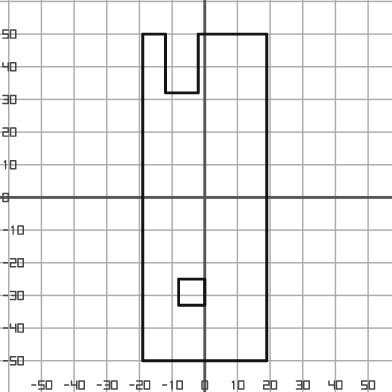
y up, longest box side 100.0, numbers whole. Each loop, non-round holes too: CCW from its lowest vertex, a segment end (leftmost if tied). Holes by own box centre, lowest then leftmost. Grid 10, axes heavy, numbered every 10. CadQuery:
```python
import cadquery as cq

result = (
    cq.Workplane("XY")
    .moveTo(-19.0, -50.0)
    .lineTo(19.0, -50.0)
    .lineTo(19.0, 50.0)
    .lineTo(-2.0, 50.0)
    .lineTo(-2.0, 32.0)
    .lineTo(-12.0, 32.0)
    .lineTo(-12.0, 50.0)
    .lineTo(-19.0, 50.0)
    .close()
    .moveTo(-8.0, -33.0)
    .lineTo(0.0, -33.0)
    .lineTo(0.0, -25.0)
    .lineTo(-8.0, -25.0)
    .close()
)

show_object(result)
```